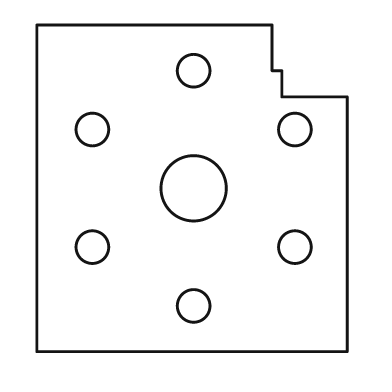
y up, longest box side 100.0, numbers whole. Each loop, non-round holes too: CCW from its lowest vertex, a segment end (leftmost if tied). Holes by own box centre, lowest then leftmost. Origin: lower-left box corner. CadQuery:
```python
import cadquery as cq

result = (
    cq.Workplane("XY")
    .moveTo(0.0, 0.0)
    .lineTo(95.0, 0.0)
    .lineTo(95.0, 78.0)
    .lineTo(75.0, 78.0)
    .lineTo(75.0, 86.0)
    .lineTo(72.0, 86.0)
    .lineTo(72.0, 100.0)
    .lineTo(0.0, 100.0)
    .close()
    .moveTo(48.0, 14.0)
    .circle(5.0)
    .moveTo(17.0, 32.0)
    .circle(5.0)
    .moveTo(79.0, 32.0)
    .circle(5.0)
    .moveTo(48.0, 50.0)
    .circle(10.0)
    .moveTo(17.0, 68.0)
    .circle(5.0)
    .moveTo(79.0, 68.0)
    .circle(5.0)
    .moveTo(48.0, 86.0)
    .circle(5.0)
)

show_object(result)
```